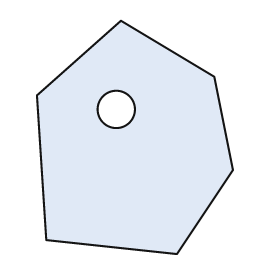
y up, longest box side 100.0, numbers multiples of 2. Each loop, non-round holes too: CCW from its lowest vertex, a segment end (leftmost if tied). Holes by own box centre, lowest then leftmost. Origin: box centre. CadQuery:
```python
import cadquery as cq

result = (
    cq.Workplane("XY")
    .moveTo(18.0, -50.0)
    .lineTo(42.0, -14.0)
    .lineTo(34.0, 26.0)
    .lineTo(-6.0, 50.0)
    .lineTo(-42.0, 18.0)
    .lineTo(-38.0, -44.0)
    .close()
    .moveTo(-8.0, 12.0)
    .circle(8.0)
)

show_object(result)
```